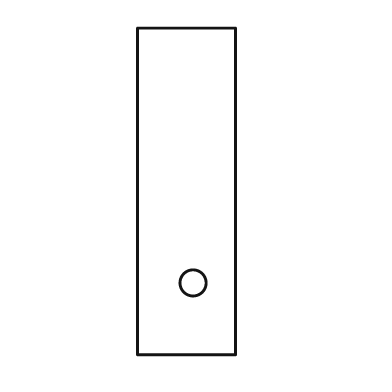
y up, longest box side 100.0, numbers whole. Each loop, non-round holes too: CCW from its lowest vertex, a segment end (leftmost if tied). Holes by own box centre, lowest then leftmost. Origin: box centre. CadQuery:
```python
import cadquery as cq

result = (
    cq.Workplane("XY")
    .moveTo(-15.0, -50.0)
    .lineTo(15.0, -50.0)
    .lineTo(15.0, 50.0)
    .lineTo(-15.0, 50.0)
    .close()
    .moveTo(2.0, -28.0)
    .circle(4.0)
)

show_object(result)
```